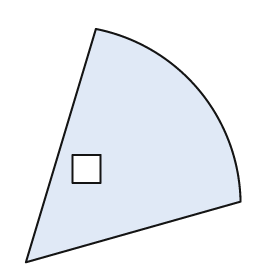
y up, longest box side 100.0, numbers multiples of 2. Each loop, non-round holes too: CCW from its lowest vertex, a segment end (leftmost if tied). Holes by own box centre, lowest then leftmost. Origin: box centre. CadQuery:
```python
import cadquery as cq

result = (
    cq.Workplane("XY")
    .moveTo(-46.0, -50.0)
    .lineTo(46.0, -24.0)
    .threePointArc((28.0, 24.0), (-16.0, 50.0))
    .close()
    .moveTo(-26.0, -16.0)
    .lineTo(-14.0, -16.0)
    .lineTo(-14.0, -4.0)
    .lineTo(-26.0, -4.0)
    .close()
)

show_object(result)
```